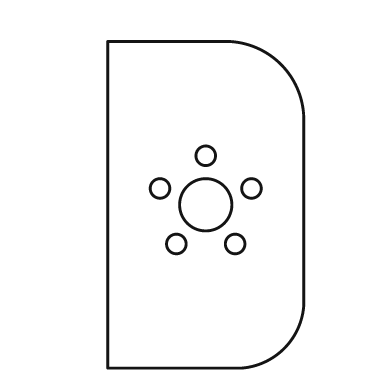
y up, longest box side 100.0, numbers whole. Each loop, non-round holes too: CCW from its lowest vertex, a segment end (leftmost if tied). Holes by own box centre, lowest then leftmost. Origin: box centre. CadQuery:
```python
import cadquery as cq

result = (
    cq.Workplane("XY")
    .moveTo(-30.0, -50.0)
    .lineTo(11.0, -50.0)
    .threePointArc((24.0, -44.0), (30.0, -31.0))
    .lineTo(30.0, 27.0)
    .threePointArc((23.0, 43.0), (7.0, 50.0))
    .lineTo(-30.0, 50.0)
    .close()
    .moveTo(-9.0, -12.0)
    .circle(3.0)
    .moveTo(9.0, -12.0)
    .circle(3.0)
    .moveTo(0.0, 0.0)
    .circle(8.0)
    .moveTo(-14.0, 5.0)
    .circle(3.0)
    .moveTo(14.0, 5.0)
    .circle(3.0)
    .moveTo(0.0, 15.0)
    .circle(3.0)
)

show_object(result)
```